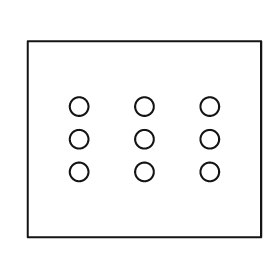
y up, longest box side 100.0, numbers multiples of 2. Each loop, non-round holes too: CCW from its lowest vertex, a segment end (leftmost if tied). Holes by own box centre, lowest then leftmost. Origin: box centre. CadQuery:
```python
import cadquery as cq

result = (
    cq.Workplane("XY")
    .moveTo(-50.0, -42.0)
    .lineTo(50.0, -42.0)
    .lineTo(50.0, 42.0)
    .lineTo(-50.0, 42.0)
    .close()
    .moveTo(-28.0, -14.0)
    .circle(4.0)
    .moveTo(0.0, -14.0)
    .circle(4.0)
    .moveTo(28.0, -14.0)
    .circle(4.0)
    .moveTo(-28.0, 0.0)
    .circle(4.0)
    .moveTo(0.0, 0.0)
    .circle(4.0)
    .moveTo(28.0, 0.0)
    .circle(4.0)
    .moveTo(-28.0, 14.0)
    .circle(4.0)
    .moveTo(0.0, 14.0)
    .circle(4.0)
    .moveTo(28.0, 14.0)
    .circle(4.0)
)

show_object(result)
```